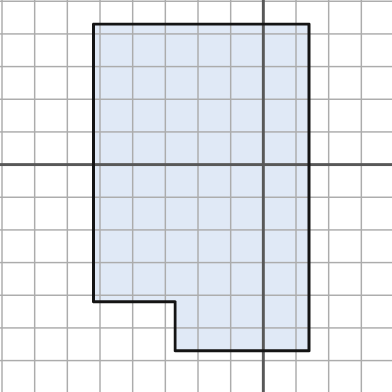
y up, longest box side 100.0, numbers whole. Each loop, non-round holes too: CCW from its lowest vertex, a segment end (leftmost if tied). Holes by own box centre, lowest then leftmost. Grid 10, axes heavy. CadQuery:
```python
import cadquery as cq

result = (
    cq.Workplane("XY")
    .moveTo(-27.0, -57.0)
    .lineTo(14.0, -57.0)
    .lineTo(14.0, 43.0)
    .lineTo(-52.0, 43.0)
    .lineTo(-52.0, -42.0)
    .lineTo(-27.0, -42.0)
    .close()
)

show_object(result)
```